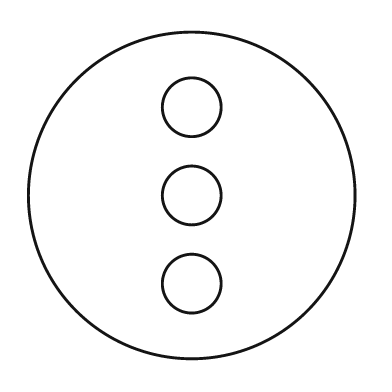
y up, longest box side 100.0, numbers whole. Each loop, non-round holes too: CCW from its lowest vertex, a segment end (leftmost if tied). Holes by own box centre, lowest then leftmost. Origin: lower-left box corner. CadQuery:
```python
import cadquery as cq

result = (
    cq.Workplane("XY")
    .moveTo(50.0, 50.0)
    .circle(50.0)
    .moveTo(50.0, 23.0)
    .circle(9.0)
    .moveTo(50.0, 50.0)
    .circle(9.0)
    .moveTo(50.0, 77.0)
    .circle(9.0)
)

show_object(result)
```